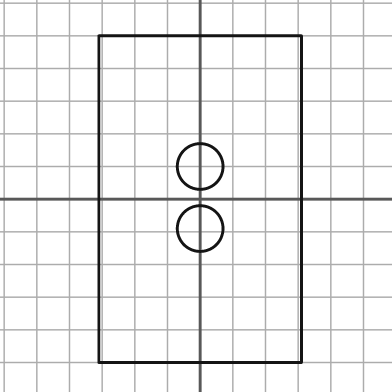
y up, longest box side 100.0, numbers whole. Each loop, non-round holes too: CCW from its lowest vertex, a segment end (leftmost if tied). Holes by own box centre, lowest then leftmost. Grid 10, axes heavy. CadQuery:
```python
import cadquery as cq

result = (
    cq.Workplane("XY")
    .moveTo(-31.0, -50.0)
    .lineTo(31.0, -50.0)
    .lineTo(31.0, 50.0)
    .lineTo(-31.0, 50.0)
    .close()
    .moveTo(0.0, -9.0)
    .circle(7.0)
    .moveTo(0.0, 10.0)
    .circle(7.0)
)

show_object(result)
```